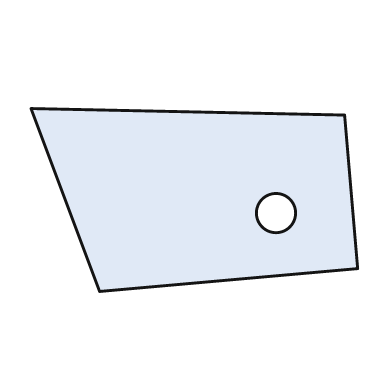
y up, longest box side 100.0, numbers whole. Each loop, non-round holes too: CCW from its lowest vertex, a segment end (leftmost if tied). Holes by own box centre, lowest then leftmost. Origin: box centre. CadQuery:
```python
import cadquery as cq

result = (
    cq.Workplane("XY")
    .moveTo(-29.0, -28.0)
    .lineTo(50.0, -21.0)
    .lineTo(46.0, 26.0)
    .lineTo(-50.0, 28.0)
    .close()
    .moveTo(25.0, -4.0)
    .circle(6.0)
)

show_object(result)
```